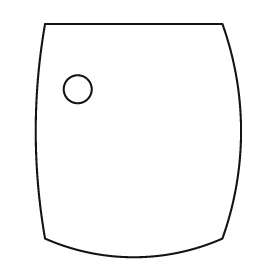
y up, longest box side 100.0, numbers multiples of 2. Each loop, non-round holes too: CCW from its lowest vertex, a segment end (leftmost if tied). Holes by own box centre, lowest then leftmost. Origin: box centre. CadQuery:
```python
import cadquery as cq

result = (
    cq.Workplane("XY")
    .moveTo(-40.0, -42.0)
    .threePointArc((-2.0, -50.0), (36.0, -42.0))
    .threePointArc((44.0, 4.0), (36.0, 50.0))
    .lineTo(-40.0, 50.0)
    .threePointArc((-44.0, 4.0), (-40.0, -42.0))
    .close()
    .moveTo(-26.0, 22.0)
    .circle(6.0)
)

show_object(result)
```